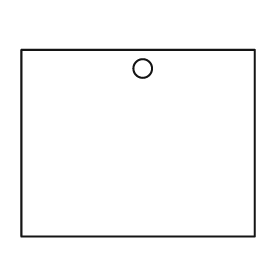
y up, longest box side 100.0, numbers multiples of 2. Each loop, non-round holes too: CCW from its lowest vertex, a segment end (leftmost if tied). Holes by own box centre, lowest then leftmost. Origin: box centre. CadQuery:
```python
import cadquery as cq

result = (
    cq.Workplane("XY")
    .moveTo(-50.0, -40.0)
    .lineTo(50.0, -40.0)
    .lineTo(50.0, 40.0)
    .lineTo(-50.0, 40.0)
    .close()
    .moveTo(2.0, 32.0)
    .circle(4.0)
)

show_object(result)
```